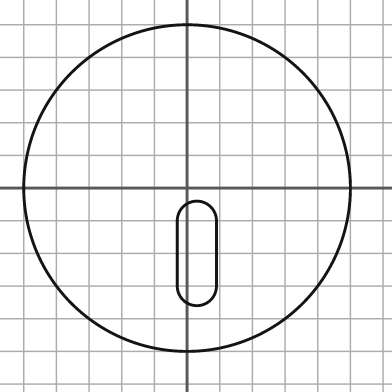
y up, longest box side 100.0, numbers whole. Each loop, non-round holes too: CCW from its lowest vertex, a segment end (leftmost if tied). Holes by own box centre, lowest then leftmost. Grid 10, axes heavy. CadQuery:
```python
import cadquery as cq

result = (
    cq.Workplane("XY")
    .moveTo(0.0, 0.0)
    .circle(50.0)
    .moveTo(-3.0, -30.0)
    .threePointArc((3.0, -36.0), (9.0, -30.0))
    .lineTo(9.0, -10.0)
    .threePointArc((3.0, -4.0), (-3.0, -10.0))
    .close()
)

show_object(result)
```